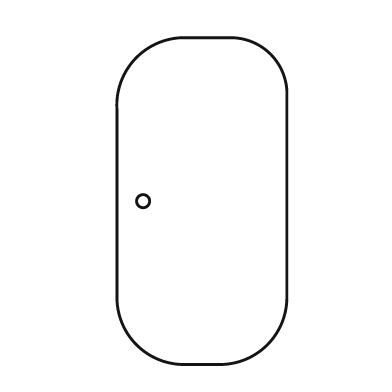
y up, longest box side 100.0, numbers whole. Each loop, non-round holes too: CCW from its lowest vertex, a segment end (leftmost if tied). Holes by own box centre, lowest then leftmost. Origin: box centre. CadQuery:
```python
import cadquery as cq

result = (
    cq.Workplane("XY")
    .moveTo(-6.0, -50.0)
    .lineTo(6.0, -50.0)
    .threePointArc((20.0, -44.0), (26.0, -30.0))
    .lineTo(26.0, 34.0)
    .threePointArc((21.0, 45.0), (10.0, 50.0))
    .lineTo(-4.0, 50.0)
    .threePointArc((-20.0, 44.0), (-26.0, 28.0))
    .lineTo(-26.0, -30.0)
    .threePointArc((-20.0, -44.0), (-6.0, -50.0))
    .close()
    .moveTo(-18.0, 0.0)
    .circle(2.0)
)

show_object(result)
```